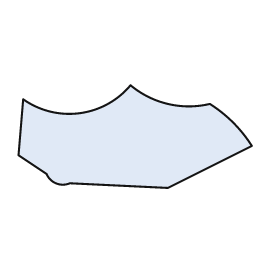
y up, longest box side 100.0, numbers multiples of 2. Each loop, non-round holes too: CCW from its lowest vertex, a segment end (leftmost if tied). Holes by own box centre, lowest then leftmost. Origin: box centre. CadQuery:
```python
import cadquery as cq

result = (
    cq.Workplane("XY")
    .moveTo(14.0, -22.0)
    .lineTo(50.0, -4.0)
    .threePointArc((42.0, 6.0), (32.0, 14.0))
    .threePointArc((14.0, 14.0), (-2.0, 22.0))
    .threePointArc((-24.0, 10.0), (-48.0, 16.0))
    .lineTo(-50.0, -8.0)
    .lineTo(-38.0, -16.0)
    .threePointArc((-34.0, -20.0), (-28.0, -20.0))
    .close()
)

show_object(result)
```